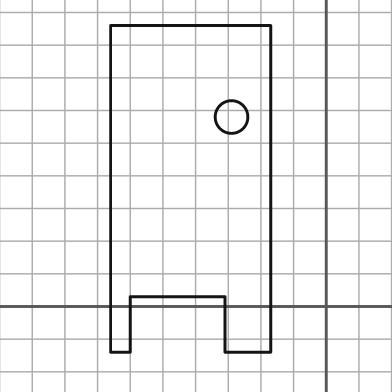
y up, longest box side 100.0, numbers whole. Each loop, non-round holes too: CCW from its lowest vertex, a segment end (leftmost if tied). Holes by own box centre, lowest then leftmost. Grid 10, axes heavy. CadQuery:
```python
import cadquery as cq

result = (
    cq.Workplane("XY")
    .moveTo(-66.0, -14.0)
    .lineTo(-60.0, -14.0)
    .lineTo(-60.0, 3.0)
    .lineTo(-31.0, 3.0)
    .lineTo(-31.0, -14.0)
    .lineTo(-17.0, -14.0)
    .lineTo(-17.0, 86.0)
    .lineTo(-66.0, 86.0)
    .close()
    .moveTo(-29.0, 58.0)
    .circle(5.0)
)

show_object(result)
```